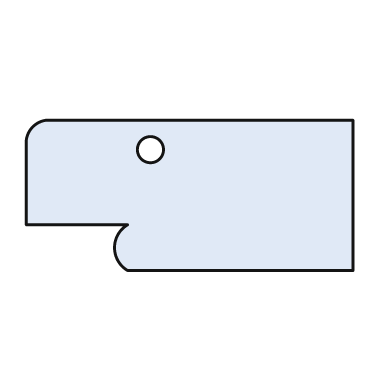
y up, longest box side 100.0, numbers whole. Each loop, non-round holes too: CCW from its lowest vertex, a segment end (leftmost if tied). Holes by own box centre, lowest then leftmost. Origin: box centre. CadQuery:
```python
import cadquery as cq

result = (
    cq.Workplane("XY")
    .moveTo(-19.0, -23.0)
    .lineTo(50.0, -23.0)
    .lineTo(50.0, 23.0)
    .lineTo(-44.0, 23.0)
    .threePointArc((-48.0, 21.0), (-50.0, 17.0))
    .lineTo(-50.0, -9.0)
    .lineTo(-19.0, -9.0)
    .threePointArc((-23.0, -16.0), (-19.0, -23.0))
    .close()
    .moveTo(-12.0, 14.0)
    .circle(4.0)
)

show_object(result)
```